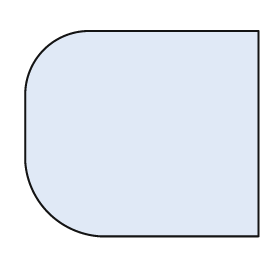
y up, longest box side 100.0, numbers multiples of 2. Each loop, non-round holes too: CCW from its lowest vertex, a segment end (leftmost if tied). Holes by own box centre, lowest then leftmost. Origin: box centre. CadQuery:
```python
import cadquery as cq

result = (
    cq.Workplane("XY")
    .moveTo(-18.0, -44.0)
    .lineTo(50.0, -44.0)
    .lineTo(50.0, 44.0)
    .lineTo(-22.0, 44.0)
    .threePointArc((-42.0, 36.0), (-50.0, 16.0))
    .lineTo(-50.0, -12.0)
    .threePointArc((-40.0, -34.0), (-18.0, -44.0))
    .close()
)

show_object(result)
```